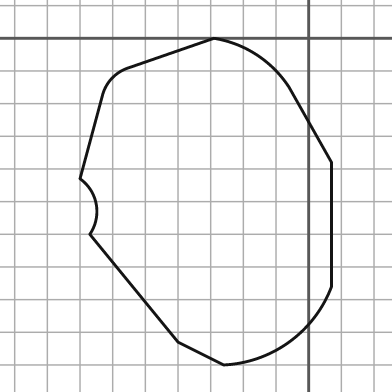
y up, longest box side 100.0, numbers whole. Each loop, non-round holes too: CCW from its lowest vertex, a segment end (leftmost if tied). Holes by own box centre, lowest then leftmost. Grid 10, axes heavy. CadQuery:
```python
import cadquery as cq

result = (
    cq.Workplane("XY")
    .moveTo(-26.0, -100.0)
    .threePointArc((-6.0, -93.0), (7.0, -76.0))
    .lineTo(7.0, -38.0)
    .lineTo(-6.0, -15.0)
    .threePointArc((-16.0, -5.0), (-29.0, 0.0))
    .lineTo(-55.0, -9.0)
    .threePointArc((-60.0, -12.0), (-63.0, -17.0))
    .lineTo(-70.0, -43.0)
    .threePointArc((-65.0, -51.0), (-67.0, -60.0))
    .lineTo(-40.0, -93.0)
    .close()
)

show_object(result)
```